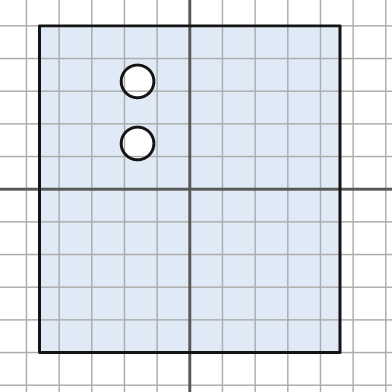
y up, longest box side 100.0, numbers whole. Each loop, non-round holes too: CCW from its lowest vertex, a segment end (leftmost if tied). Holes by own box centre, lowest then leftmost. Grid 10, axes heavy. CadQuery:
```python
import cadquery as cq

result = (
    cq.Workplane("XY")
    .moveTo(-46.0, -50.0)
    .lineTo(46.0, -50.0)
    .lineTo(46.0, 50.0)
    .lineTo(-46.0, 50.0)
    .close()
    .moveTo(-16.0, 14.0)
    .circle(5.0)
    .moveTo(-16.0, 33.0)
    .circle(5.0)
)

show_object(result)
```